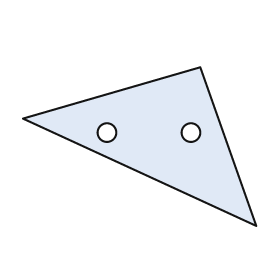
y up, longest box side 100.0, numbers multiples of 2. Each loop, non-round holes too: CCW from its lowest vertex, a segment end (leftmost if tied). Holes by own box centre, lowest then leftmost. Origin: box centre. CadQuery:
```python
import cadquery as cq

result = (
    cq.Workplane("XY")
    .moveTo(50.0, -34.0)
    .lineTo(26.0, 34.0)
    .lineTo(-50.0, 12.0)
    .close()
    .moveTo(-14.0, 6.0)
    .circle(4.0)
    .moveTo(22.0, 6.0)
    .circle(4.0)
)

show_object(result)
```